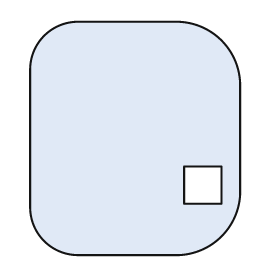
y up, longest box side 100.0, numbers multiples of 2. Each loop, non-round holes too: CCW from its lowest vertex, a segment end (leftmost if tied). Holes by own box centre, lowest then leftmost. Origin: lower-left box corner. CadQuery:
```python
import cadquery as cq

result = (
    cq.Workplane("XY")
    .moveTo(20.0, 0.0)
    .lineTo(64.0, 0.0)
    .threePointArc((82.0, 8.0), (90.0, 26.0))
    .lineTo(90.0, 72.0)
    .threePointArc((82.0, 92.0), (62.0, 100.0))
    .lineTo(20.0, 100.0)
    .threePointArc((6.0, 94.0), (0.0, 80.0))
    .lineTo(0.0, 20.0)
    .threePointArc((6.0, 6.0), (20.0, 0.0))
    .close()
    .moveTo(66.0, 22.0)
    .lineTo(82.0, 22.0)
    .lineTo(82.0, 38.0)
    .lineTo(66.0, 38.0)
    .close()
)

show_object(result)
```